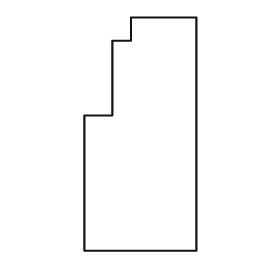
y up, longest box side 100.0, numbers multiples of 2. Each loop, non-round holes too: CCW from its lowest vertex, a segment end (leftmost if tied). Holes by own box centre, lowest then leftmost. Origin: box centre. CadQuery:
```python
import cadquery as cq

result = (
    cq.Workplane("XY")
    .moveTo(-24.0, -50.0)
    .lineTo(24.0, -50.0)
    .lineTo(24.0, 50.0)
    .lineTo(-4.0, 50.0)
    .lineTo(-4.0, 40.0)
    .lineTo(-12.0, 40.0)
    .lineTo(-12.0, 8.0)
    .lineTo(-24.0, 8.0)
    .close()
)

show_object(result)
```